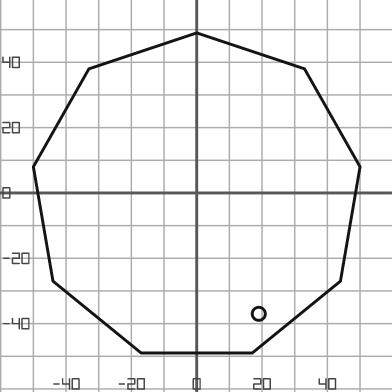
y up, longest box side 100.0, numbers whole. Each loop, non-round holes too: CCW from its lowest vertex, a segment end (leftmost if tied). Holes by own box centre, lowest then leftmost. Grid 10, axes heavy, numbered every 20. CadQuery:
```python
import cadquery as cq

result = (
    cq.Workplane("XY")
    .moveTo(-17.0, -49.0)
    .lineTo(17.0, -49.0)
    .lineTo(44.0, -27.0)
    .lineTo(50.0, 8.0)
    .lineTo(33.0, 38.0)
    .lineTo(0.0, 49.0)
    .lineTo(-33.0, 38.0)
    .lineTo(-50.0, 8.0)
    .lineTo(-44.0, -27.0)
    .close()
    .moveTo(19.0, -37.0)
    .circle(2.0)
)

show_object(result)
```